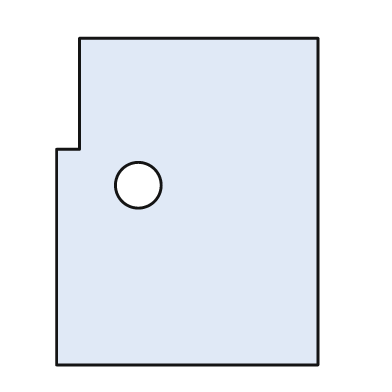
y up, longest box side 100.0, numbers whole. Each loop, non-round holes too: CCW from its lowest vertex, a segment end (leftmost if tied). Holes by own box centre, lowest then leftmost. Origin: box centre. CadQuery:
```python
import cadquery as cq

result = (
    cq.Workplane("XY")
    .moveTo(-40.0, -50.0)
    .lineTo(40.0, -50.0)
    .lineTo(40.0, 50.0)
    .lineTo(-33.0, 50.0)
    .lineTo(-33.0, 16.0)
    .lineTo(-40.0, 16.0)
    .close()
    .moveTo(-15.0, 5.0)
    .circle(7.0)
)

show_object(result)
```